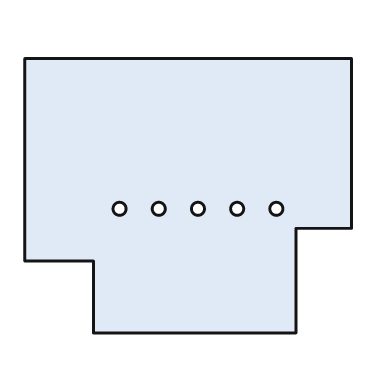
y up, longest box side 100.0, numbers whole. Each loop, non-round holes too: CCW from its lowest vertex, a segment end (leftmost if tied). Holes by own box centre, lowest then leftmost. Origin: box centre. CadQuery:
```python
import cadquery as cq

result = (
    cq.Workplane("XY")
    .moveTo(-29.0, -42.0)
    .lineTo(33.0, -42.0)
    .lineTo(33.0, -10.0)
    .lineTo(50.0, -10.0)
    .lineTo(50.0, 42.0)
    .lineTo(-50.0, 42.0)
    .lineTo(-50.0, -20.0)
    .lineTo(-29.0, -20.0)
    .close()
    .moveTo(-21.0, -4.0)
    .circle(2.0)
    .moveTo(-9.0, -4.0)
    .circle(2.0)
    .moveTo(3.0, -4.0)
    .circle(2.0)
    .moveTo(15.0, -4.0)
    .circle(2.0)
    .moveTo(27.0, -4.0)
    .circle(2.0)
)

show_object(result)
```